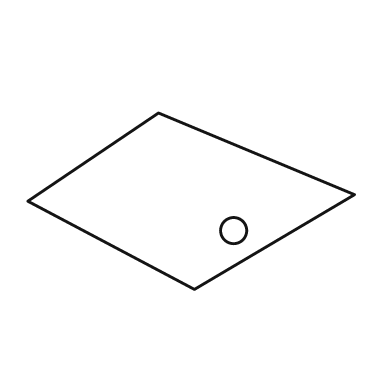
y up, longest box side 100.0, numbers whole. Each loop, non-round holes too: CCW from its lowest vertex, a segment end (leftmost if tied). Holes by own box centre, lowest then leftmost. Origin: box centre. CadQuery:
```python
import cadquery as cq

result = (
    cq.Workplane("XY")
    .moveTo(1.0, -27.0)
    .lineTo(50.0, 2.0)
    .lineTo(-10.0, 27.0)
    .lineTo(-50.0, 0.0)
    .close()
    .moveTo(13.0, -9.0)
    .circle(4.0)
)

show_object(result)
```